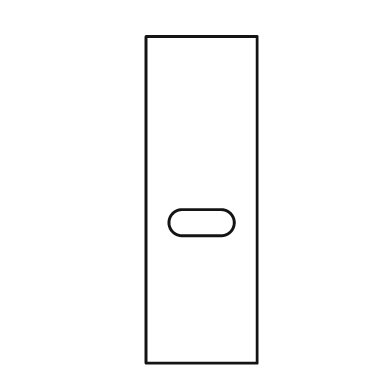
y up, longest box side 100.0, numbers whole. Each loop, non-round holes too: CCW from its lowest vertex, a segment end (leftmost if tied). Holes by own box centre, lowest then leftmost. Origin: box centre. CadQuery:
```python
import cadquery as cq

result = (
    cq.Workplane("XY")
    .moveTo(-17.0, -50.0)
    .lineTo(17.0, -50.0)
    .lineTo(17.0, 50.0)
    .lineTo(-17.0, 50.0)
    .close()
    .moveTo(-6.0, -11.0)
    .lineTo(6.0, -11.0)
    .threePointArc((10.0, -7.0), (6.0, -3.0))
    .lineTo(-6.0, -3.0)
    .threePointArc((-10.0, -7.0), (-6.0, -11.0))
    .close()
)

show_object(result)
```